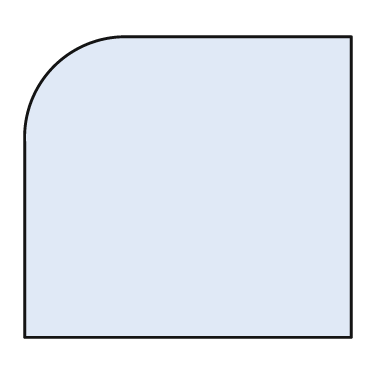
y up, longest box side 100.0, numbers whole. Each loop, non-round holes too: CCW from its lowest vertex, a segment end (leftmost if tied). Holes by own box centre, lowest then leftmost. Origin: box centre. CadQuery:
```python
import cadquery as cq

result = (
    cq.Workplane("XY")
    .moveTo(-50.0, -46.0)
    .lineTo(50.0, -46.0)
    .lineTo(50.0, 46.0)
    .lineTo(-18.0, 46.0)
    .threePointArc((-41.0, 37.0), (-50.0, 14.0))
    .close()
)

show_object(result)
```